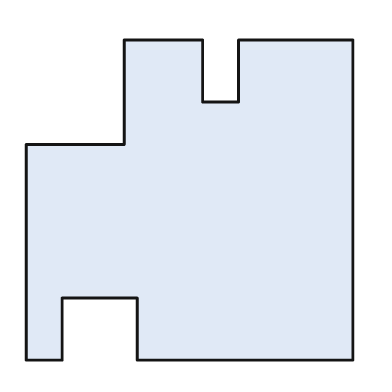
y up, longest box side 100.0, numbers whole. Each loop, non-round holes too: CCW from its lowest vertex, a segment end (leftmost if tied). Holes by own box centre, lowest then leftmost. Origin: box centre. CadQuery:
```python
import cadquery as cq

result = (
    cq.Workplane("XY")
    .moveTo(-50.0, -49.0)
    .lineTo(-39.0, -49.0)
    .lineTo(-39.0, -30.0)
    .lineTo(-16.0, -30.0)
    .lineTo(-16.0, -49.0)
    .lineTo(50.0, -49.0)
    .lineTo(50.0, 49.0)
    .lineTo(15.0, 49.0)
    .lineTo(15.0, 30.0)
    .lineTo(4.0, 30.0)
    .lineTo(4.0, 49.0)
    .lineTo(-20.0, 49.0)
    .lineTo(-20.0, 17.0)
    .lineTo(-50.0, 17.0)
    .close()
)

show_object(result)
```